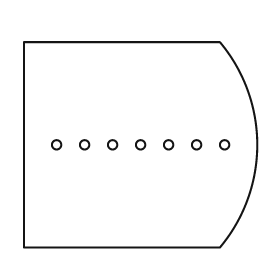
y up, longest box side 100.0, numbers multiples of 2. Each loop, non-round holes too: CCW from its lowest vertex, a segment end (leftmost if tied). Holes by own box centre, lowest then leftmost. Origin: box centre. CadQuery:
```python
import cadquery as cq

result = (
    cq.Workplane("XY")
    .moveTo(-50.0, -44.0)
    .lineTo(34.0, -44.0)
    .threePointArc((50.0, 0.0), (34.0, 44.0))
    .lineTo(-50.0, 44.0)
    .close()
    .moveTo(-36.0, 0.0)
    .circle(2.0)
    .moveTo(-24.0, 0.0)
    .circle(2.0)
    .moveTo(-12.0, 0.0)
    .circle(2.0)
    .moveTo(0.0, 0.0)
    .circle(2.0)
    .moveTo(12.0, 0.0)
    .circle(2.0)
    .moveTo(24.0, 0.0)
    .circle(2.0)
    .moveTo(36.0, 0.0)
    .circle(2.0)
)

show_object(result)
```